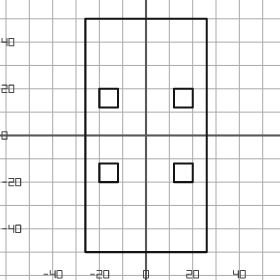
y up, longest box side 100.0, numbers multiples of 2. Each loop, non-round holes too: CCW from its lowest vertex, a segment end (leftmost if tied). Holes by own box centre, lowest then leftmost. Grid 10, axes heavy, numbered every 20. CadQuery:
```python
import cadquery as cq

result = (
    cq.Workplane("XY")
    .moveTo(-26.0, -50.0)
    .lineTo(26.0, -50.0)
    .lineTo(26.0, 50.0)
    .lineTo(-26.0, 50.0)
    .close()
    .moveTo(-20.0, -20.0)
    .lineTo(-12.0, -20.0)
    .lineTo(-12.0, -12.0)
    .lineTo(-20.0, -12.0)
    .close()
    .moveTo(12.0, -20.0)
    .lineTo(20.0, -20.0)
    .lineTo(20.0, -12.0)
    .lineTo(12.0, -12.0)
    .close()
    .moveTo(-20.0, 12.0)
    .lineTo(-12.0, 12.0)
    .lineTo(-12.0, 20.0)
    .lineTo(-20.0, 20.0)
    .close()
    .moveTo(12.0, 12.0)
    .lineTo(20.0, 12.0)
    .lineTo(20.0, 20.0)
    .lineTo(12.0, 20.0)
    .close()
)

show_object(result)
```